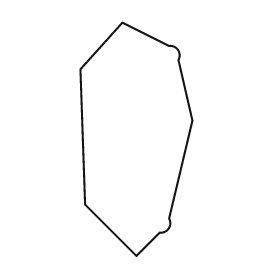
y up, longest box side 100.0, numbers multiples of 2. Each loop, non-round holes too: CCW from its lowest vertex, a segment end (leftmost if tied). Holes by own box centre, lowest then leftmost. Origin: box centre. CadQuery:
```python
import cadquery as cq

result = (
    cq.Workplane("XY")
    .moveTo(0.0, -50.0)
    .lineTo(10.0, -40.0)
    .threePointArc((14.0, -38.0), (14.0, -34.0))
    .lineTo(24.0, 8.0)
    .lineTo(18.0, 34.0)
    .threePointArc((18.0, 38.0), (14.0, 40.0))
    .lineTo(-6.0, 50.0)
    .lineTo(-24.0, 30.0)
    .lineTo(-22.0, -28.0)
    .close()
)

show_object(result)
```